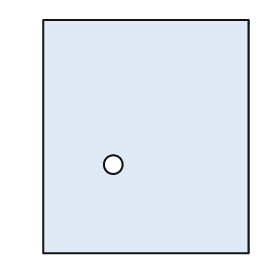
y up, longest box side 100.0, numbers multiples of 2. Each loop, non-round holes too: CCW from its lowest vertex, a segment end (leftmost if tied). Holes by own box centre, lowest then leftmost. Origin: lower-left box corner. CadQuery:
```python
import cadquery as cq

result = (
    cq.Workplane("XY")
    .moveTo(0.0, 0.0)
    .lineTo(88.0, 0.0)
    .lineTo(88.0, 100.0)
    .lineTo(0.0, 100.0)
    .close()
    .moveTo(30.0, 38.0)
    .circle(4.0)
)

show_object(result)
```